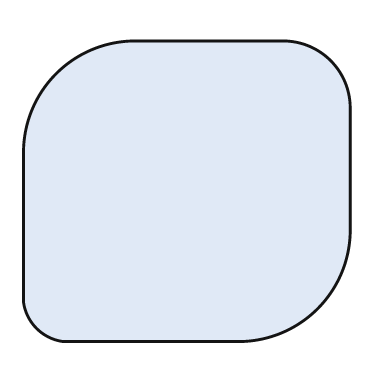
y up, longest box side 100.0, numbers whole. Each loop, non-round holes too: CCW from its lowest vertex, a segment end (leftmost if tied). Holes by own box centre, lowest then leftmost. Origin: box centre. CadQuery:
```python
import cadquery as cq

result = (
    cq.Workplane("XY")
    .moveTo(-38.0, -46.0)
    .lineTo(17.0, -46.0)
    .threePointArc((40.0, -36.0), (50.0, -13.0))
    .lineTo(50.0, 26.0)
    .threePointArc((44.0, 40.0), (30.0, 46.0))
    .lineTo(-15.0, 46.0)
    .threePointArc((-40.0, 36.0), (-50.0, 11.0))
    .lineTo(-50.0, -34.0)
    .threePointArc((-46.0, -42.0), (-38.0, -46.0))
    .close()
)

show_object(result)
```